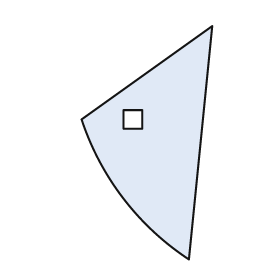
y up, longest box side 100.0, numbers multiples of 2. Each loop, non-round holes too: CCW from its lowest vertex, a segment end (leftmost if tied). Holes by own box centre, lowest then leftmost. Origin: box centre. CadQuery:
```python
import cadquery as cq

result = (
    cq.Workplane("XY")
    .moveTo(18.0, -50.0)
    .lineTo(28.0, 50.0)
    .lineTo(-28.0, 10.0)
    .threePointArc((-10.0, -24.0), (18.0, -50.0))
    .close()
    .moveTo(-10.0, 6.0)
    .lineTo(-2.0, 6.0)
    .lineTo(-2.0, 14.0)
    .lineTo(-10.0, 14.0)
    .close()
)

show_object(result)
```